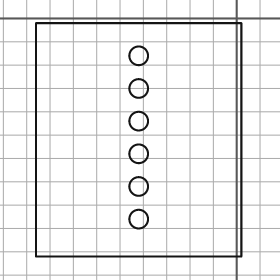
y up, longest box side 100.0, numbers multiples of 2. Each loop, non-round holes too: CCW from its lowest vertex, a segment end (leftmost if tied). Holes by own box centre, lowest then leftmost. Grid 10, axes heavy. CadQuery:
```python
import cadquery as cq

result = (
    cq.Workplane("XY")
    .moveTo(-86.0, -102.0)
    .lineTo(2.0, -102.0)
    .lineTo(2.0, -2.0)
    .lineTo(-86.0, -2.0)
    .close()
    .moveTo(-42.0, -86.0)
    .circle(4.0)
    .moveTo(-42.0, -72.0)
    .circle(4.0)
    .moveTo(-42.0, -58.0)
    .circle(4.0)
    .moveTo(-42.0, -44.0)
    .circle(4.0)
    .moveTo(-42.0, -30.0)
    .circle(4.0)
    .moveTo(-42.0, -16.0)
    .circle(4.0)
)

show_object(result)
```